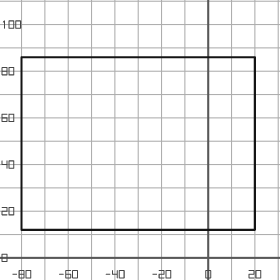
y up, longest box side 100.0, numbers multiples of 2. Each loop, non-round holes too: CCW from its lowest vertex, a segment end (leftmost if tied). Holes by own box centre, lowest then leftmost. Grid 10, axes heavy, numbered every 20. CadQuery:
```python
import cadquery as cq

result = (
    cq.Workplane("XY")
    .moveTo(-80.0, 12.0)
    .lineTo(20.0, 12.0)
    .lineTo(20.0, 86.0)
    .lineTo(-80.0, 86.0)
    .close()
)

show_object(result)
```